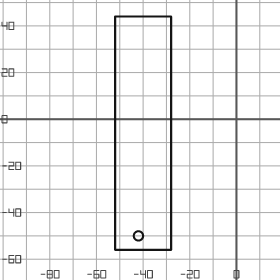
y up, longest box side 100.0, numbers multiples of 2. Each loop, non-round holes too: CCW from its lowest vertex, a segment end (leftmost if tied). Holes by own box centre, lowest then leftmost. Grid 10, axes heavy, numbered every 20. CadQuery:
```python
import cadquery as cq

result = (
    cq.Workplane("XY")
    .moveTo(-52.0, -56.0)
    .lineTo(-28.0, -56.0)
    .lineTo(-28.0, 44.0)
    .lineTo(-52.0, 44.0)
    .close()
    .moveTo(-42.0, -50.0)
    .circle(2.0)
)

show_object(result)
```